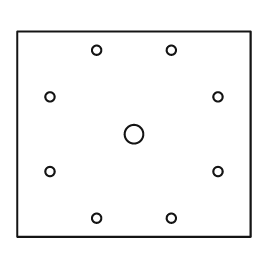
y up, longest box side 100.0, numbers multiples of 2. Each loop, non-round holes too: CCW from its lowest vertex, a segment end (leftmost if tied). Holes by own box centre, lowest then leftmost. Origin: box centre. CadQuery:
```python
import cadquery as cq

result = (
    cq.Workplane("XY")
    .moveTo(-50.0, -44.0)
    .lineTo(50.0, -44.0)
    .lineTo(50.0, 44.0)
    .lineTo(-50.0, 44.0)
    .close()
    .moveTo(-16.0, -36.0)
    .circle(2.0)
    .moveTo(16.0, -36.0)
    .circle(2.0)
    .moveTo(-36.0, -16.0)
    .circle(2.0)
    .moveTo(36.0, -16.0)
    .circle(2.0)
    .moveTo(0.0, 0.0)
    .circle(4.0)
    .moveTo(-36.0, 16.0)
    .circle(2.0)
    .moveTo(36.0, 16.0)
    .circle(2.0)
    .moveTo(-16.0, 36.0)
    .circle(2.0)
    .moveTo(16.0, 36.0)
    .circle(2.0)
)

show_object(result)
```